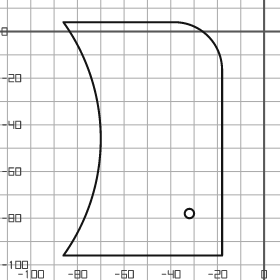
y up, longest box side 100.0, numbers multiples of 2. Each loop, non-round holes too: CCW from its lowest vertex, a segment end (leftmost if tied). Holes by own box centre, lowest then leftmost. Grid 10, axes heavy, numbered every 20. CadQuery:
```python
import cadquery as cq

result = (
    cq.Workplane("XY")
    .moveTo(-86.0, -96.0)
    .lineTo(-18.0, -96.0)
    .lineTo(-18.0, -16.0)
    .threePointArc((-24.0, -2.0), (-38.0, 4.0))
    .lineTo(-86.0, 4.0)
    .threePointArc((-70.0, -46.0), (-86.0, -96.0))
    .close()
    .moveTo(-32.0, -78.0)
    .circle(2.0)
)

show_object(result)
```